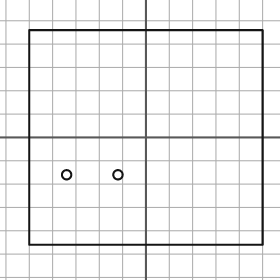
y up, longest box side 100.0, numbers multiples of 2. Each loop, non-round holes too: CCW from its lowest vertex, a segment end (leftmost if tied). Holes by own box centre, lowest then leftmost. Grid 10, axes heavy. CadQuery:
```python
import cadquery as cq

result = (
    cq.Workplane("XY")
    .moveTo(-50.0, -46.0)
    .lineTo(50.0, -46.0)
    .lineTo(50.0, 46.0)
    .lineTo(-50.0, 46.0)
    .close()
    .moveTo(-34.0, -16.0)
    .circle(2.0)
    .moveTo(-12.0, -16.0)
    .circle(2.0)
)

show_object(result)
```